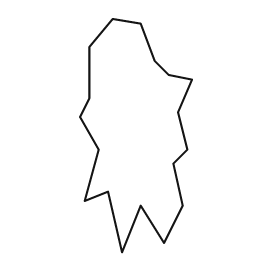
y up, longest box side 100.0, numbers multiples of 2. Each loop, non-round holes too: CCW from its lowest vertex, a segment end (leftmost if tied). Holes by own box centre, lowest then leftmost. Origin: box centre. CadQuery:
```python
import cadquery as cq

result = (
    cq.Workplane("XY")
    .moveTo(-6.0, -50.0)
    .lineTo(2.0, -30.0)
    .lineTo(12.0, -46.0)
    .lineTo(20.0, -30.0)
    .lineTo(16.0, -12.0)
    .lineTo(22.0, -6.0)
    .lineTo(18.0, 10.0)
    .lineTo(24.0, 24.0)
    .lineTo(14.0, 26.0)
    .lineTo(8.0, 32.0)
    .lineTo(2.0, 48.0)
    .lineTo(-10.0, 50.0)
    .lineTo(-20.0, 38.0)
    .lineTo(-20.0, 16.0)
    .lineTo(-24.0, 8.0)
    .lineTo(-16.0, -6.0)
    .lineTo(-22.0, -28.0)
    .lineTo(-12.0, -24.0)
    .close()
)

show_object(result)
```